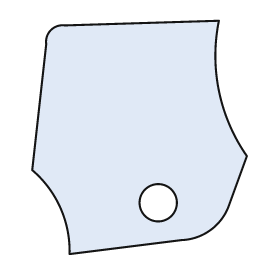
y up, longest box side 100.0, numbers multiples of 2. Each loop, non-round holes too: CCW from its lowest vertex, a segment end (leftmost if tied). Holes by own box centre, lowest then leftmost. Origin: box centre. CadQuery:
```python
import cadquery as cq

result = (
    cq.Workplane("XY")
    .moveTo(-30.0, -50.0)
    .lineTo(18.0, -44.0)
    .threePointArc((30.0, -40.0), (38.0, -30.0))
    .lineTo(46.0, -8.0)
    .threePointArc((34.0, 20.0), (34.0, 50.0))
    .lineTo(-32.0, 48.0)
    .threePointArc((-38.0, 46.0), (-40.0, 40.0))
    .lineTo(-46.0, -14.0)
    .threePointArc((-34.0, -30.0), (-30.0, -50.0))
    .close()
    .moveTo(8.0, -28.0)
    .circle(8.0)
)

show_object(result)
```